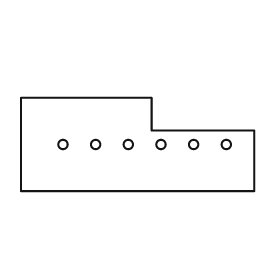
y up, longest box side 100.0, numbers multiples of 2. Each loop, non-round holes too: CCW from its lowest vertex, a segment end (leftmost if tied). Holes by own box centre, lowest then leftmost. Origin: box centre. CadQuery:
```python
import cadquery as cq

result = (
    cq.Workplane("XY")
    .moveTo(-50.0, -20.0)
    .lineTo(50.0, -20.0)
    .lineTo(50.0, 6.0)
    .lineTo(6.0, 6.0)
    .lineTo(6.0, 20.0)
    .lineTo(-50.0, 20.0)
    .close()
    .moveTo(-32.0, 0.0)
    .circle(2.0)
    .moveTo(-18.0, 0.0)
    .circle(2.0)
    .moveTo(-4.0, 0.0)
    .circle(2.0)
    .moveTo(10.0, 0.0)
    .circle(2.0)
    .moveTo(24.0, 0.0)
    .circle(2.0)
    .moveTo(38.0, 0.0)
    .circle(2.0)
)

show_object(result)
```